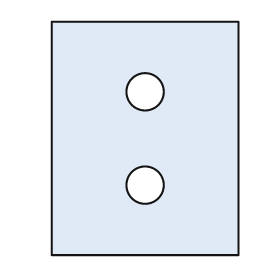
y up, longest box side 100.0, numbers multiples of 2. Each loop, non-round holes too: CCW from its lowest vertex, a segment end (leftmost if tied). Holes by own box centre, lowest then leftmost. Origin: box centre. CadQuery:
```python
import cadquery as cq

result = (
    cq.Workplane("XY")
    .moveTo(-40.0, -50.0)
    .lineTo(40.0, -50.0)
    .lineTo(40.0, 50.0)
    .lineTo(-40.0, 50.0)
    .close()
    .moveTo(0.0, -20.0)
    .circle(8.0)
    .moveTo(0.0, 20.0)
    .circle(8.0)
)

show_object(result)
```